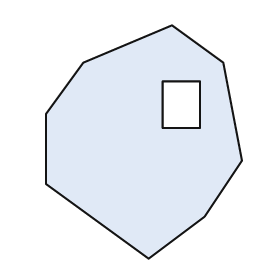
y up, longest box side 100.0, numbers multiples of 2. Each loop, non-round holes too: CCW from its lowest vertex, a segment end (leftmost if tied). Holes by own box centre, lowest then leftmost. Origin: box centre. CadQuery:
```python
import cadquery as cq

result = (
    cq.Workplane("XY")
    .moveTo(2.0, -50.0)
    .lineTo(26.0, -32.0)
    .lineTo(42.0, -8.0)
    .lineTo(34.0, 34.0)
    .lineTo(12.0, 50.0)
    .lineTo(-26.0, 34.0)
    .lineTo(-42.0, 12.0)
    .lineTo(-42.0, -18.0)
    .close()
    .moveTo(8.0, 6.0)
    .lineTo(24.0, 6.0)
    .lineTo(24.0, 26.0)
    .lineTo(8.0, 26.0)
    .close()
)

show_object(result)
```